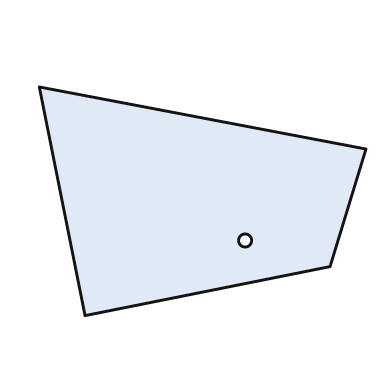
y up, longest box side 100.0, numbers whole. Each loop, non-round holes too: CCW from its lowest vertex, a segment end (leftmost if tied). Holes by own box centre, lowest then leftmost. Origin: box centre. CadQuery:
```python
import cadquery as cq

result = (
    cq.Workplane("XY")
    .moveTo(-36.0, -35.0)
    .lineTo(39.0, -20.0)
    .lineTo(50.0, 16.0)
    .lineTo(-50.0, 35.0)
    .close()
    .moveTo(13.0, -12.0)
    .circle(2.0)
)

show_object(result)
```